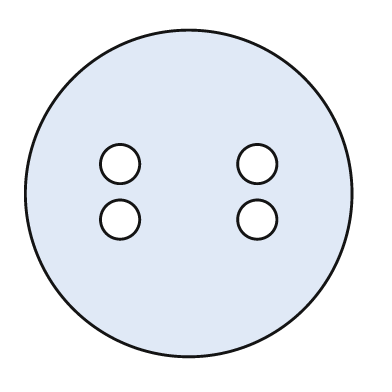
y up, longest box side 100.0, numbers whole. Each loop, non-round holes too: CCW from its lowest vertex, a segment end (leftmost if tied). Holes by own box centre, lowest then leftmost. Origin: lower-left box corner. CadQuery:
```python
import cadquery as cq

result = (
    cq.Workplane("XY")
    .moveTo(50.0, 50.0)
    .circle(50.0)
    .moveTo(29.0, 42.0)
    .circle(6.0)
    .moveTo(71.0, 42.0)
    .circle(6.0)
    .moveTo(29.0, 59.0)
    .circle(6.0)
    .moveTo(71.0, 59.0)
    .circle(6.0)
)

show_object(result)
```